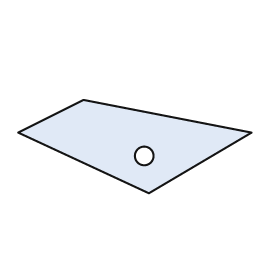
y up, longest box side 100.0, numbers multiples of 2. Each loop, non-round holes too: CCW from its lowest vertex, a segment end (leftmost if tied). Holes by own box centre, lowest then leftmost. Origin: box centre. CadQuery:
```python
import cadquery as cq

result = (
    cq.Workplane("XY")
    .moveTo(6.0, -20.0)
    .lineTo(50.0, 6.0)
    .lineTo(-22.0, 20.0)
    .lineTo(-50.0, 6.0)
    .close()
    .moveTo(4.0, -4.0)
    .circle(4.0)
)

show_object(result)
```